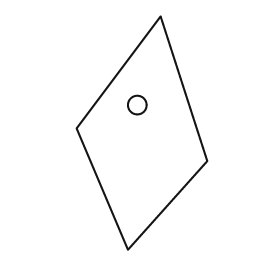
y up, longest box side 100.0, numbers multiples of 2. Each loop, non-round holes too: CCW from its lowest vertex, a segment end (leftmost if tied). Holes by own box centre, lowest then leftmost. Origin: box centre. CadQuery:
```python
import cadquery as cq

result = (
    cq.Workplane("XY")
    .moveTo(-6.0, -50.0)
    .lineTo(28.0, -12.0)
    .lineTo(8.0, 50.0)
    .lineTo(-28.0, 2.0)
    .close()
    .moveTo(-2.0, 12.0)
    .circle(4.0)
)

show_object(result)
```